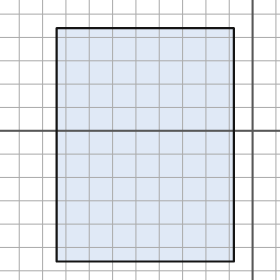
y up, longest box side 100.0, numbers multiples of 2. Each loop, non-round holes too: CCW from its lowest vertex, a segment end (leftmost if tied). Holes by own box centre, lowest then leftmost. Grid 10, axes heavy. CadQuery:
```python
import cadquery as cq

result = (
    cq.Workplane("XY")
    .moveTo(-84.0, -56.0)
    .lineTo(-8.0, -56.0)
    .lineTo(-8.0, 44.0)
    .lineTo(-84.0, 44.0)
    .close()
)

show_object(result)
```